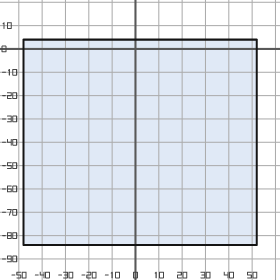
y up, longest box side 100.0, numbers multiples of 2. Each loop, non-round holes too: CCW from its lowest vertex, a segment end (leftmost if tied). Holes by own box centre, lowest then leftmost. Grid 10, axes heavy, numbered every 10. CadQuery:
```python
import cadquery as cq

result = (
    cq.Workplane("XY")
    .moveTo(-48.0, -84.0)
    .lineTo(52.0, -84.0)
    .lineTo(52.0, 4.0)
    .lineTo(-48.0, 4.0)
    .close()
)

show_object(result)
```